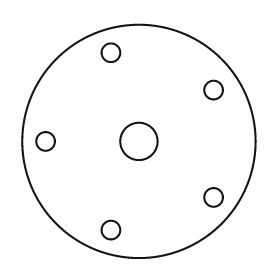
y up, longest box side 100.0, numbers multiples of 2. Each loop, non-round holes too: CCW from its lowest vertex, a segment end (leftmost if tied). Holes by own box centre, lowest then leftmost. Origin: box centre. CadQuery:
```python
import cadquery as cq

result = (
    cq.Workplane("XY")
    .moveTo(0.0, 0.0)
    .circle(50.0)
    .moveTo(-12.0, -38.0)
    .circle(4.0)
    .moveTo(32.0, -24.0)
    .circle(4.0)
    .moveTo(-40.0, 0.0)
    .circle(4.0)
    .moveTo(0.0, 0.0)
    .circle(8.0)
    .moveTo(32.0, 22.0)
    .circle(4.0)
    .moveTo(-12.0, 38.0)
    .circle(4.0)
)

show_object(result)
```